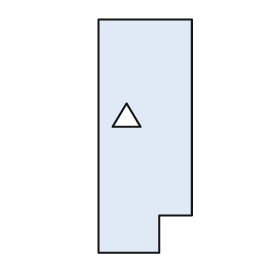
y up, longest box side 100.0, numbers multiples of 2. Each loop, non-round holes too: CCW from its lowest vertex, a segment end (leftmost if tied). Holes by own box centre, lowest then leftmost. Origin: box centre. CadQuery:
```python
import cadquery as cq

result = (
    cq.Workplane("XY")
    .moveTo(-20.0, -50.0)
    .lineTo(6.0, -50.0)
    .lineTo(6.0, -34.0)
    .lineTo(20.0, -34.0)
    .lineTo(20.0, 50.0)
    .lineTo(-20.0, 50.0)
    .close()
    .moveTo(-14.0, 4.0)
    .lineTo(-2.0, 4.0)
    .lineTo(-8.0, 14.0)
    .close()
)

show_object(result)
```